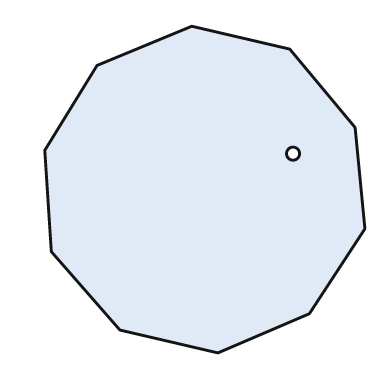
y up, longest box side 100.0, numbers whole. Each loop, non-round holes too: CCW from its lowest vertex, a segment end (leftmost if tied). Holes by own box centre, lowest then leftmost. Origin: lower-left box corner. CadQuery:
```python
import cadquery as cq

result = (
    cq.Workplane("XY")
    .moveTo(53.0, 0.0)
    .lineTo(81.0, 12.0)
    .lineTo(98.0, 38.0)
    .lineTo(95.0, 69.0)
    .lineTo(75.0, 93.0)
    .lineTo(45.0, 100.0)
    .lineTo(16.0, 88.0)
    .lineTo(0.0, 62.0)
    .lineTo(2.0, 31.0)
    .lineTo(23.0, 7.0)
    .close()
    .moveTo(76.0, 61.0)
    .circle(2.0)
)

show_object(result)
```